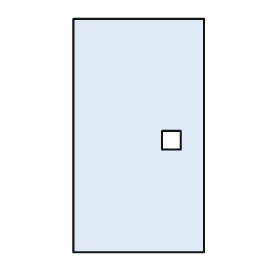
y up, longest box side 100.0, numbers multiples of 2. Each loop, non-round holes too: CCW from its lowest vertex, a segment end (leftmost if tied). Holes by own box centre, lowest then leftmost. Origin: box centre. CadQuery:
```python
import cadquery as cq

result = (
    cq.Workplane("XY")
    .moveTo(-28.0, -50.0)
    .lineTo(28.0, -50.0)
    .lineTo(28.0, 50.0)
    .lineTo(-28.0, 50.0)
    .close()
    .moveTo(10.0, -6.0)
    .lineTo(18.0, -6.0)
    .lineTo(18.0, 2.0)
    .lineTo(10.0, 2.0)
    .close()
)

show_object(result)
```